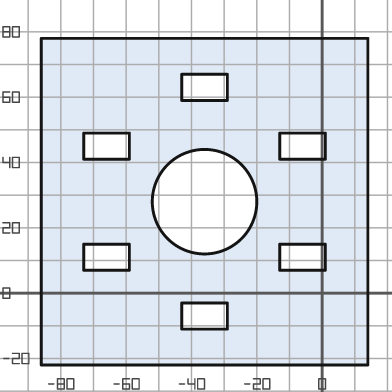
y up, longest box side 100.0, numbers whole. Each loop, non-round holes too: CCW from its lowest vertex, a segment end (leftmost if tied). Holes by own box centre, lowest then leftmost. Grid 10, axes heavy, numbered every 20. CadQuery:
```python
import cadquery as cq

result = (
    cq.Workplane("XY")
    .moveTo(-86.0, -22.0)
    .lineTo(14.0, -22.0)
    .lineTo(14.0, 78.0)
    .lineTo(-86.0, 78.0)
    .close()
    .moveTo(-43.0, -11.0)
    .lineTo(-29.0, -11.0)
    .lineTo(-29.0, -3.0)
    .lineTo(-43.0, -3.0)
    .close()
    .moveTo(-73.0, 7.0)
    .lineTo(-59.0, 7.0)
    .lineTo(-59.0, 15.0)
    .lineTo(-73.0, 15.0)
    .close()
    .moveTo(-13.0, 7.0)
    .lineTo(1.0, 7.0)
    .lineTo(1.0, 15.0)
    .lineTo(-13.0, 15.0)
    .close()
    .moveTo(-36.0, 28.0)
    .circle(16.0)
    .moveTo(-73.0, 41.0)
    .lineTo(-59.0, 41.0)
    .lineTo(-59.0, 49.0)
    .lineTo(-73.0, 49.0)
    .close()
    .moveTo(-13.0, 41.0)
    .lineTo(1.0, 41.0)
    .lineTo(1.0, 49.0)
    .lineTo(-13.0, 49.0)
    .close()
    .moveTo(-43.0, 59.0)
    .lineTo(-29.0, 59.0)
    .lineTo(-29.0, 67.0)
    .lineTo(-43.0, 67.0)
    .close()
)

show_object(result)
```